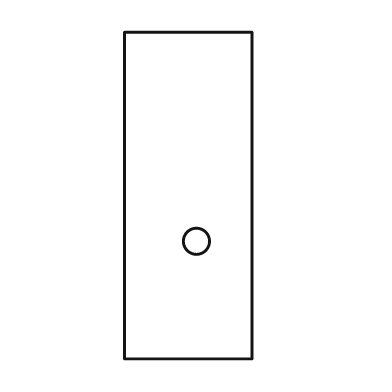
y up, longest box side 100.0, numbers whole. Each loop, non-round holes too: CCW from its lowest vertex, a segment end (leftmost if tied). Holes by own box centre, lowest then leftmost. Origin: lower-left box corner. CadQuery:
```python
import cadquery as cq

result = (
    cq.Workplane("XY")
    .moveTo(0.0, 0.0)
    .lineTo(39.0, 0.0)
    .lineTo(39.0, 100.0)
    .lineTo(0.0, 100.0)
    .close()
    .moveTo(22.0, 36.0)
    .circle(4.0)
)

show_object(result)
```